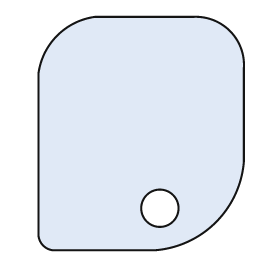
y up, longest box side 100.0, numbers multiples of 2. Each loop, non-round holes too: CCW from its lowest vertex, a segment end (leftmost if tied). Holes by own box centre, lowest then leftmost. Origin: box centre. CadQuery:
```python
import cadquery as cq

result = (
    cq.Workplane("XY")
    .moveTo(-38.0, -50.0)
    .lineTo(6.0, -50.0)
    .threePointArc((32.0, -38.0), (44.0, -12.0))
    .lineTo(44.0, 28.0)
    .threePointArc((38.0, 44.0), (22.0, 50.0))
    .lineTo(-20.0, 50.0)
    .threePointArc((-36.0, 42.0), (-44.0, 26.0))
    .lineTo(-44.0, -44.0)
    .threePointArc((-42.0, -48.0), (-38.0, -50.0))
    .close()
    .moveTo(8.0, -32.0)
    .circle(8.0)
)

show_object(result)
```